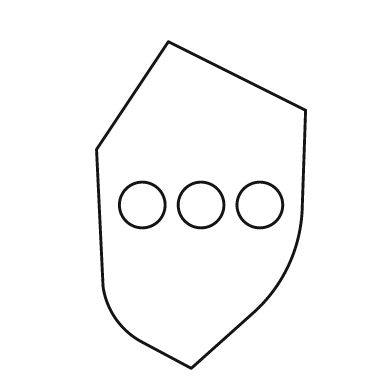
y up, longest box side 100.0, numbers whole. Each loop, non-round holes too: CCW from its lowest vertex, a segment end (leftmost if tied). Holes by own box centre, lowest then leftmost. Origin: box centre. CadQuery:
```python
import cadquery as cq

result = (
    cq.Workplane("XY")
    .moveTo(-3.0, -50.0)
    .lineTo(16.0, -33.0)
    .threePointArc((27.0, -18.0), (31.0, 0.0))
    .lineTo(32.0, 29.0)
    .lineTo(-10.0, 50.0)
    .lineTo(-32.0, 17.0)
    .lineTo(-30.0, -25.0)
    .threePointArc((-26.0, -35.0), (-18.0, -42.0))
    .close()
    .moveTo(-18.0, 0.0)
    .circle(7.0)
    .moveTo(0.0, 0.0)
    .circle(7.0)
    .moveTo(18.0, 0.0)
    .circle(7.0)
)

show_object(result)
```